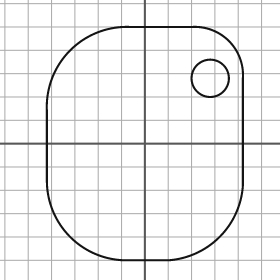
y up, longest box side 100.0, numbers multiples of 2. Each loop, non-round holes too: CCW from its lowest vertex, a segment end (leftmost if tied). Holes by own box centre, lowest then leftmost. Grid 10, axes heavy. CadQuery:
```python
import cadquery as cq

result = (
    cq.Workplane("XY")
    .moveTo(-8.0, -50.0)
    .lineTo(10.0, -50.0)
    .threePointArc((32.0, -40.0), (42.0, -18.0))
    .lineTo(42.0, 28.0)
    .threePointArc((36.0, 44.0), (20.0, 50.0))
    .lineTo(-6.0, 50.0)
    .threePointArc((-32.0, 40.0), (-42.0, 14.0))
    .lineTo(-42.0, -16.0)
    .threePointArc((-32.0, -40.0), (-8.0, -50.0))
    .close()
    .moveTo(28.0, 28.0)
    .circle(8.0)
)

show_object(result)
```